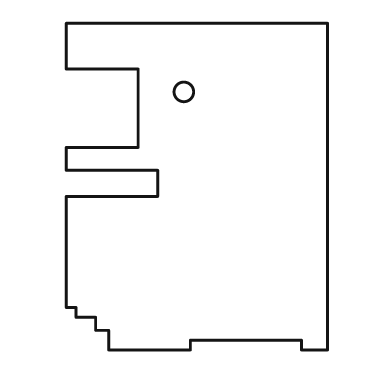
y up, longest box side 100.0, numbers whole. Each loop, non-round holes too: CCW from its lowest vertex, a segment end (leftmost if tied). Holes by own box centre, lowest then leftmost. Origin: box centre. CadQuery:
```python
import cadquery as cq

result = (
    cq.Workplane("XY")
    .moveTo(-27.0, -50.0)
    .lineTo(-2.0, -50.0)
    .lineTo(-2.0, -47.0)
    .lineTo(32.0, -47.0)
    .lineTo(32.0, -50.0)
    .lineTo(40.0, -50.0)
    .lineTo(40.0, 50.0)
    .lineTo(-40.0, 50.0)
    .lineTo(-40.0, 36.0)
    .lineTo(-18.0, 36.0)
    .lineTo(-18.0, 12.0)
    .lineTo(-40.0, 12.0)
    .lineTo(-40.0, 5.0)
    .lineTo(-12.0, 5.0)
    .lineTo(-12.0, -3.0)
    .lineTo(-40.0, -3.0)
    .lineTo(-40.0, -37.0)
    .lineTo(-37.0, -37.0)
    .lineTo(-37.0, -40.0)
    .lineTo(-31.0, -40.0)
    .lineTo(-31.0, -44.0)
    .lineTo(-27.0, -44.0)
    .close()
    .moveTo(-4.0, 29.0)
    .circle(3.0)
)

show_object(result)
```